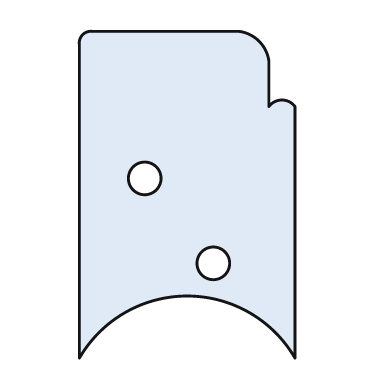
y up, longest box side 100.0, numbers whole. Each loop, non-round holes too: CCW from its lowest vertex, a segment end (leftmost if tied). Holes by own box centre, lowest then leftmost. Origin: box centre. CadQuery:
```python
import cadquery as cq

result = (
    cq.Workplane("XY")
    .moveTo(-33.0, -50.0)
    .threePointArc((0.0, -31.0), (33.0, -50.0))
    .lineTo(33.0, 27.0)
    .threePointArc((29.0, 29.0), (25.0, 27.0))
    .lineTo(25.0, 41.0)
    .threePointArc((22.0, 47.0), (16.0, 50.0))
    .lineTo(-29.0, 50.0)
    .threePointArc((-32.0, 49.0), (-33.0, 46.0))
    .close()
    .moveTo(8.0, -21.0)
    .circle(5.0)
    .moveTo(-13.0, 5.0)
    .circle(5.0)
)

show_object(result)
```